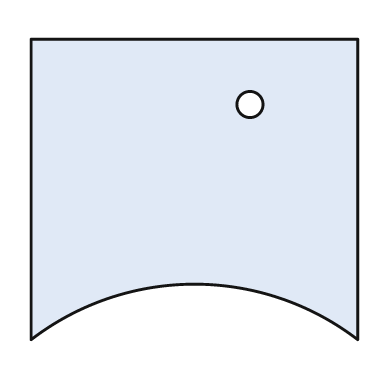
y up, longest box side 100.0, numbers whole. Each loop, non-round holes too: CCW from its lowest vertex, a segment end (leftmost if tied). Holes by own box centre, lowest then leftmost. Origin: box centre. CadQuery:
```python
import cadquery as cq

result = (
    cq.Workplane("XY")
    .moveTo(-50.0, -46.0)
    .threePointArc((0.0, -29.0), (50.0, -46.0))
    .lineTo(50.0, 46.0)
    .lineTo(-50.0, 46.0)
    .close()
    .moveTo(17.0, 26.0)
    .circle(4.0)
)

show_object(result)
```